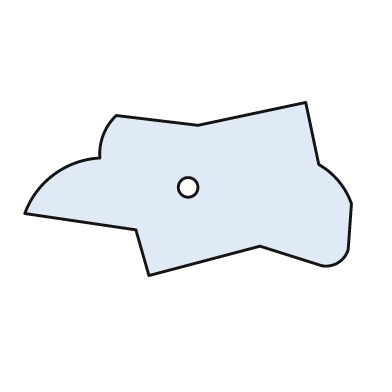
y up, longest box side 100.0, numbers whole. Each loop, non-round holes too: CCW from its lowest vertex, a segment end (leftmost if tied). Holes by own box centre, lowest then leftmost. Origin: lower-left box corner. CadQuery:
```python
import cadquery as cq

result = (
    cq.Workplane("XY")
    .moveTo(38.0, 0.0)
    .lineTo(72.0, 9.0)
    .lineTo(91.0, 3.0)
    .threePointArc((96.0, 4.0), (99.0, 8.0))
    .lineTo(100.0, 22.0)
    .threePointArc((96.0, 29.0), (90.0, 34.0))
    .lineTo(86.0, 53.0)
    .lineTo(53.0, 46.0)
    .lineTo(28.0, 49.0)
    .threePointArc((24.0, 43.0), (23.0, 36.0))
    .threePointArc((9.0, 31.0), (0.0, 19.0))
    .lineTo(34.0, 14.0)
    .close()
    .moveTo(50.0, 27.0)
    .circle(3.0)
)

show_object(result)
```